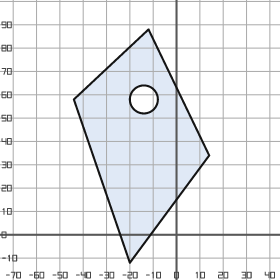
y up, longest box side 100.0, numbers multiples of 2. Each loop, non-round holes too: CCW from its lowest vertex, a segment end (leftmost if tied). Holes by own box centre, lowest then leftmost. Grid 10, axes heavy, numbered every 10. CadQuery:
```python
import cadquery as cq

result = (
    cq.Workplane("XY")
    .moveTo(-20.0, -12.0)
    .lineTo(14.0, 34.0)
    .lineTo(-12.0, 88.0)
    .lineTo(-44.0, 58.0)
    .close()
    .moveTo(-14.0, 58.0)
    .circle(6.0)
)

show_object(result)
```